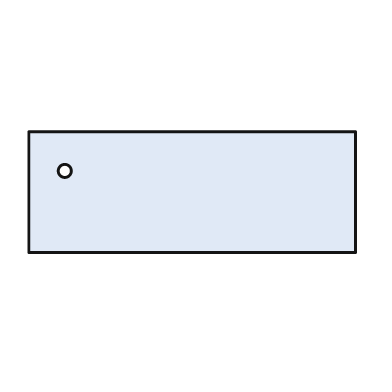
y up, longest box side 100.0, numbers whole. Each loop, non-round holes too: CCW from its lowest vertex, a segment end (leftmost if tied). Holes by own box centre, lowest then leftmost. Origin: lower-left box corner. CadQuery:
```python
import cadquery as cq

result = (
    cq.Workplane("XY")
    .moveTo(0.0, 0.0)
    .lineTo(100.0, 0.0)
    .lineTo(100.0, 37.0)
    .lineTo(0.0, 37.0)
    .close()
    .moveTo(11.0, 25.0)
    .circle(2.0)
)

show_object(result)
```